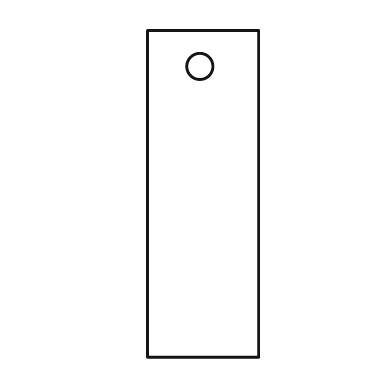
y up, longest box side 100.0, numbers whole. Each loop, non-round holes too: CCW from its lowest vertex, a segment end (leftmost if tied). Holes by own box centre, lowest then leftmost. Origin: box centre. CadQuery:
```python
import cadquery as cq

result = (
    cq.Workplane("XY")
    .moveTo(-17.0, -50.0)
    .lineTo(17.0, -50.0)
    .lineTo(17.0, 50.0)
    .lineTo(-17.0, 50.0)
    .close()
    .moveTo(-1.0, 39.0)
    .circle(4.0)
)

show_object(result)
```